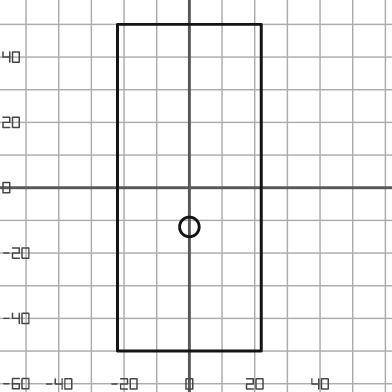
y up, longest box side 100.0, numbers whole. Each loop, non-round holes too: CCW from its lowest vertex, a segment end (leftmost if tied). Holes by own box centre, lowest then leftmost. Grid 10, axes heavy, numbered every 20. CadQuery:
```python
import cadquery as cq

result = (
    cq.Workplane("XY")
    .moveTo(-22.0, -50.0)
    .lineTo(22.0, -50.0)
    .lineTo(22.0, 50.0)
    .lineTo(-22.0, 50.0)
    .close()
    .moveTo(0.0, -12.0)
    .circle(3.0)
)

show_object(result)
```